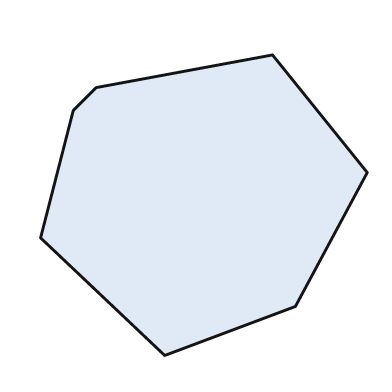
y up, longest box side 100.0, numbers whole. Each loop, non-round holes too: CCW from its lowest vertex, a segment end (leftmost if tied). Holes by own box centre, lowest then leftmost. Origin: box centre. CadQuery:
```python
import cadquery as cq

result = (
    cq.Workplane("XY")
    .moveTo(-12.0, -46.0)
    .lineTo(28.0, -31.0)
    .lineTo(50.0, 10.0)
    .lineTo(21.0, 46.0)
    .lineTo(-33.0, 36.0)
    .lineTo(-40.0, 29.0)
    .lineTo(-50.0, -10.0)
    .close()
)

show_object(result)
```